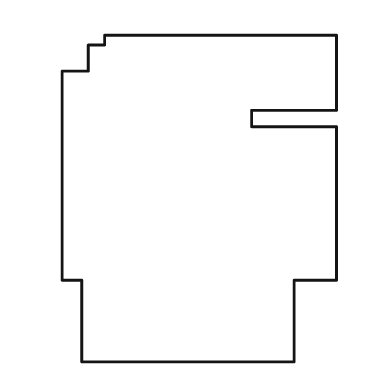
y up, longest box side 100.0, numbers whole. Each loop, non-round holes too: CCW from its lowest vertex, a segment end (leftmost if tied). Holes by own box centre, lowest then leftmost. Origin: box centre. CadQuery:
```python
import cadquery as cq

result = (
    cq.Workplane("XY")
    .moveTo(-36.0, -50.0)
    .lineTo(29.0, -50.0)
    .lineTo(29.0, -25.0)
    .lineTo(42.0, -25.0)
    .lineTo(42.0, 22.0)
    .lineTo(16.0, 22.0)
    .lineTo(16.0, 27.0)
    .lineTo(42.0, 27.0)
    .lineTo(42.0, 50.0)
    .lineTo(-29.0, 50.0)
    .lineTo(-29.0, 47.0)
    .lineTo(-34.0, 47.0)
    .lineTo(-34.0, 39.0)
    .lineTo(-42.0, 39.0)
    .lineTo(-42.0, -25.0)
    .lineTo(-36.0, -25.0)
    .close()
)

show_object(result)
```